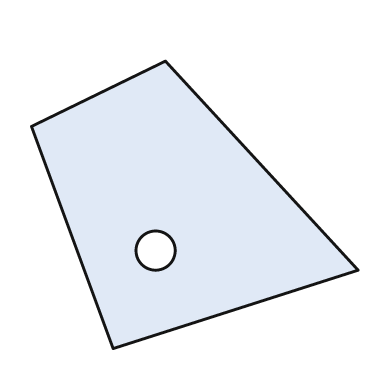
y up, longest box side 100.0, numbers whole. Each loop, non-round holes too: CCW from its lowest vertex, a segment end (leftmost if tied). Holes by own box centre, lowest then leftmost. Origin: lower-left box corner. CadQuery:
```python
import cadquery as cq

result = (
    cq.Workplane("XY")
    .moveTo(25.0, 0.0)
    .lineTo(100.0, 24.0)
    .lineTo(41.0, 88.0)
    .lineTo(0.0, 68.0)
    .close()
    .moveTo(38.0, 30.0)
    .circle(6.0)
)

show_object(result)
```